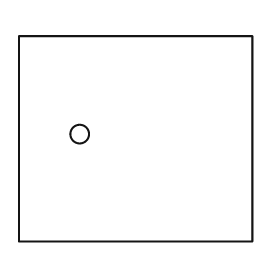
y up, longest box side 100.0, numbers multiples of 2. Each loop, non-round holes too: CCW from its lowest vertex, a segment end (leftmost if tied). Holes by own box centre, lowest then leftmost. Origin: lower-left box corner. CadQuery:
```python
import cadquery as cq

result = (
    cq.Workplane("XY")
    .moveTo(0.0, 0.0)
    .lineTo(100.0, 0.0)
    .lineTo(100.0, 88.0)
    .lineTo(0.0, 88.0)
    .close()
    .moveTo(26.0, 46.0)
    .circle(4.0)
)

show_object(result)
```